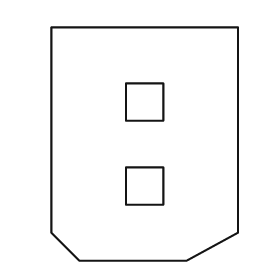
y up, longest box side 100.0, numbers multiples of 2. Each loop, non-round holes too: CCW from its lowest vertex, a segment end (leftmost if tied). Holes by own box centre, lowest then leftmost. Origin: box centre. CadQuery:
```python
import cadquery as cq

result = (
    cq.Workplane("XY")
    .moveTo(-28.0, -50.0)
    .lineTo(18.0, -50.0)
    .lineTo(40.0, -38.0)
    .lineTo(40.0, 50.0)
    .lineTo(-40.0, 50.0)
    .lineTo(-40.0, -38.0)
    .close()
    .moveTo(-8.0, -26.0)
    .lineTo(8.0, -26.0)
    .lineTo(8.0, -10.0)
    .lineTo(-8.0, -10.0)
    .close()
    .moveTo(-8.0, 10.0)
    .lineTo(8.0, 10.0)
    .lineTo(8.0, 26.0)
    .lineTo(-8.0, 26.0)
    .close()
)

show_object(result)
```